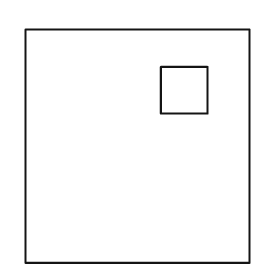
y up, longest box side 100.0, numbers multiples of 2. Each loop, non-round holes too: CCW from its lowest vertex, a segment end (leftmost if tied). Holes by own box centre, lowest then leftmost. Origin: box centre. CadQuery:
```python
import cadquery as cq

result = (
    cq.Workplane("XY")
    .moveTo(-48.0, -50.0)
    .lineTo(48.0, -50.0)
    .lineTo(48.0, 50.0)
    .lineTo(-48.0, 50.0)
    .close()
    .moveTo(10.0, 14.0)
    .lineTo(30.0, 14.0)
    .lineTo(30.0, 34.0)
    .lineTo(10.0, 34.0)
    .close()
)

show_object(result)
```